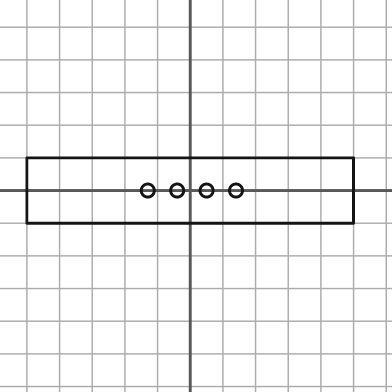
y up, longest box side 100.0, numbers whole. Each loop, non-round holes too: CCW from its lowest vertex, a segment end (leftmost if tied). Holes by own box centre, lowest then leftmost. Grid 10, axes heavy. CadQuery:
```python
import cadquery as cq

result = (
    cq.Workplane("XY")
    .moveTo(-50.0, -10.0)
    .lineTo(50.0, -10.0)
    .lineTo(50.0, 10.0)
    .lineTo(-50.0, 10.0)
    .close()
    .moveTo(-13.0, 0.0)
    .circle(2.0)
    .moveTo(-4.0, 0.0)
    .circle(2.0)
    .moveTo(5.0, 0.0)
    .circle(2.0)
    .moveTo(14.0, 0.0)
    .circle(2.0)
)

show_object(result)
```